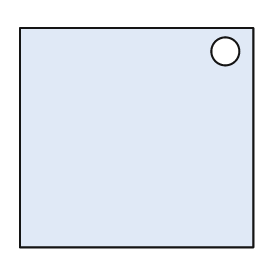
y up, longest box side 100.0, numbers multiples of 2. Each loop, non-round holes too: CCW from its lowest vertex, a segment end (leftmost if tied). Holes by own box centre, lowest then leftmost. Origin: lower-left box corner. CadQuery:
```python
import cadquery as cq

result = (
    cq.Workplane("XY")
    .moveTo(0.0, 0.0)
    .lineTo(100.0, 0.0)
    .lineTo(100.0, 94.0)
    .lineTo(0.0, 94.0)
    .close()
    .moveTo(88.0, 84.0)
    .circle(6.0)
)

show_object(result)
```